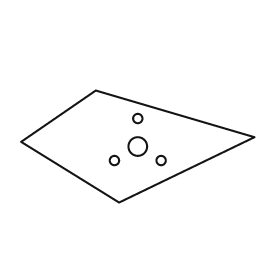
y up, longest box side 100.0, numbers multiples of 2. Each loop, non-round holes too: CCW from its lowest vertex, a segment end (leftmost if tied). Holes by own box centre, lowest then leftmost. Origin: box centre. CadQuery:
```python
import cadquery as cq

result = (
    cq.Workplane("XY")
    .moveTo(-8.0, -24.0)
    .lineTo(50.0, 4.0)
    .lineTo(-18.0, 24.0)
    .lineTo(-50.0, 2.0)
    .close()
    .moveTo(-10.0, -6.0)
    .circle(2.0)
    .moveTo(10.0, -6.0)
    .circle(2.0)
    .moveTo(0.0, 0.0)
    .circle(4.0)
    .moveTo(0.0, 12.0)
    .circle(2.0)
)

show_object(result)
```